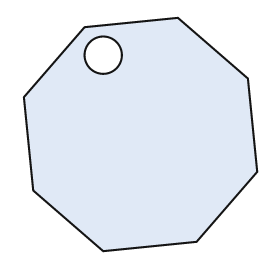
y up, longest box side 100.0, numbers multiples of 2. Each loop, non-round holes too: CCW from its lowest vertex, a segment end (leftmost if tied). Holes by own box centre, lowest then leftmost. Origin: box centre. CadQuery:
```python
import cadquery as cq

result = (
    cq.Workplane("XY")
    .moveTo(-16.0, -50.0)
    .lineTo(24.0, -46.0)
    .lineTo(50.0, -16.0)
    .lineTo(46.0, 24.0)
    .lineTo(16.0, 50.0)
    .lineTo(-24.0, 46.0)
    .lineTo(-50.0, 16.0)
    .lineTo(-46.0, -24.0)
    .close()
    .moveTo(-16.0, 34.0)
    .circle(8.0)
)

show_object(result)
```